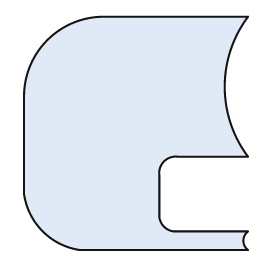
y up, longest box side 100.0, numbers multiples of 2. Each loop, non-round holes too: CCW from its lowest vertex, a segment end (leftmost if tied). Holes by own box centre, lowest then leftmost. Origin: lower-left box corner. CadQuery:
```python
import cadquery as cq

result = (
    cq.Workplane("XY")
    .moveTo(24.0, 0.0)
    .lineTo(96.0, 0.0)
    .threePointArc((94.0, 4.0), (96.0, 8.0))
    .lineTo(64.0, 8.0)
    .threePointArc((60.0, 10.0), (58.0, 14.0))
    .lineTo(58.0, 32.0)
    .threePointArc((60.0, 38.0), (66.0, 40.0))
    .lineTo(96.0, 40.0)
    .threePointArc((86.0, 70.0), (96.0, 100.0))
    .lineTo(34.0, 100.0)
    .threePointArc((10.0, 90.0), (0.0, 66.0))
    .lineTo(0.0, 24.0)
    .threePointArc((8.0, 8.0), (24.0, 0.0))
    .close()
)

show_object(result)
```